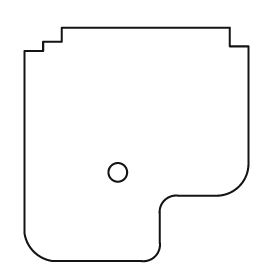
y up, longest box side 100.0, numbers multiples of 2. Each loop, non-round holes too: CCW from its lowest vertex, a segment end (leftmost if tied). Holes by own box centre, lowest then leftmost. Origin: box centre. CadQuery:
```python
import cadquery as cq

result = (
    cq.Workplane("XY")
    .moveTo(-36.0, -50.0)
    .lineTo(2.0, -50.0)
    .threePointArc((8.0, -48.0), (10.0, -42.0))
    .lineTo(10.0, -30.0)
    .threePointArc((12.0, -24.0), (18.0, -22.0))
    .lineTo(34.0, -22.0)
    .threePointArc((44.0, -18.0), (48.0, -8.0))
    .lineTo(48.0, 42.0)
    .lineTo(40.0, 42.0)
    .lineTo(40.0, 50.0)
    .lineTo(-32.0, 50.0)
    .lineTo(-32.0, 44.0)
    .lineTo(-40.0, 44.0)
    .lineTo(-40.0, 40.0)
    .lineTo(-48.0, 40.0)
    .lineTo(-48.0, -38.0)
    .threePointArc((-44.0, -46.0), (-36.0, -50.0))
    .close()
    .moveTo(-8.0, -12.0)
    .circle(4.0)
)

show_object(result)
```